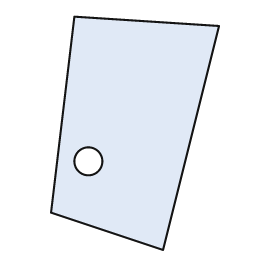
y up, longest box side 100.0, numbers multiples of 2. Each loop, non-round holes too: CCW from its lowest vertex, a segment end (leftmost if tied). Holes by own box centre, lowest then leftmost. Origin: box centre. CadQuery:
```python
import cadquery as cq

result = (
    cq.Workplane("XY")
    .moveTo(12.0, -50.0)
    .lineTo(36.0, 46.0)
    .lineTo(-26.0, 50.0)
    .lineTo(-36.0, -34.0)
    .close()
    .moveTo(-20.0, -12.0)
    .circle(6.0)
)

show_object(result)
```